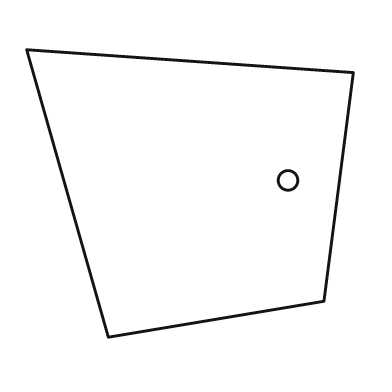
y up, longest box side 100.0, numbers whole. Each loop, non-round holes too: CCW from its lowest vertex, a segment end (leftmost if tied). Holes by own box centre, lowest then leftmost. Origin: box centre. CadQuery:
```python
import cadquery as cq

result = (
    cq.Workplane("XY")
    .moveTo(-25.0, -44.0)
    .lineTo(41.0, -33.0)
    .lineTo(50.0, 37.0)
    .lineTo(-50.0, 44.0)
    .close()
    .moveTo(30.0, 4.0)
    .circle(3.0)
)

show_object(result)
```